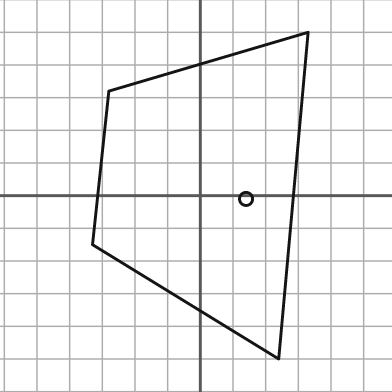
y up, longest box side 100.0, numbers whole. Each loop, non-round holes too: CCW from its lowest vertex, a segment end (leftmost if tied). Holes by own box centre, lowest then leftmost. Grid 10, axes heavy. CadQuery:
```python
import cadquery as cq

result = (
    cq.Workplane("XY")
    .moveTo(24.0, -50.0)
    .lineTo(33.0, 50.0)
    .lineTo(-28.0, 32.0)
    .lineTo(-33.0, -15.0)
    .close()
    .moveTo(14.0, -1.0)
    .circle(2.0)
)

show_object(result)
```